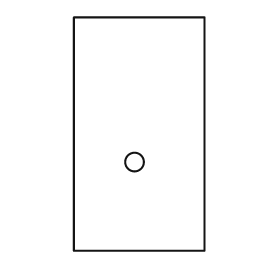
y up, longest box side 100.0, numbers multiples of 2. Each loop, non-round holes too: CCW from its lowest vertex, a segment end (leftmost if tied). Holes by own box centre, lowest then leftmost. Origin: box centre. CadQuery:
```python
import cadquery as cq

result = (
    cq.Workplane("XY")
    .moveTo(-28.0, -50.0)
    .lineTo(28.0, -50.0)
    .lineTo(28.0, 50.0)
    .lineTo(-28.0, 50.0)
    .close()
    .moveTo(-2.0, -12.0)
    .circle(4.0)
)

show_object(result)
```